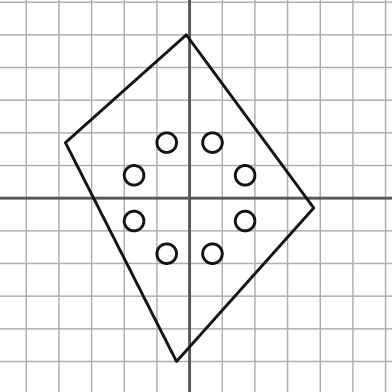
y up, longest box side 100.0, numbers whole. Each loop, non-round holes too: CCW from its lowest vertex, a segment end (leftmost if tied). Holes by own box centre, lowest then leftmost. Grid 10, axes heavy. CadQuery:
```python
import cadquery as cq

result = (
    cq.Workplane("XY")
    .moveTo(-4.0, -50.0)
    .lineTo(38.0, -3.0)
    .lineTo(-1.0, 50.0)
    .lineTo(-38.0, 17.0)
    .close()
    .moveTo(-7.0, -17.0)
    .circle(3.0)
    .moveTo(7.0, -17.0)
    .circle(3.0)
    .moveTo(-17.0, -7.0)
    .circle(3.0)
    .moveTo(17.0, -7.0)
    .circle(3.0)
    .moveTo(-17.0, 7.0)
    .circle(3.0)
    .moveTo(17.0, 7.0)
    .circle(3.0)
    .moveTo(-7.0, 17.0)
    .circle(3.0)
    .moveTo(7.0, 17.0)
    .circle(3.0)
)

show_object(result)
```